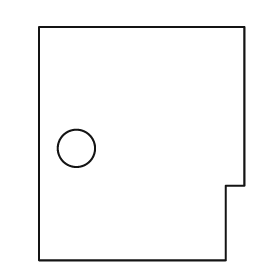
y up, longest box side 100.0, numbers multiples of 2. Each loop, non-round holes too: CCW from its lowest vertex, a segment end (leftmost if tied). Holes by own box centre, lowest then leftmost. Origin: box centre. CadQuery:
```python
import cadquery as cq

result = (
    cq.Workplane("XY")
    .moveTo(-44.0, -50.0)
    .lineTo(36.0, -50.0)
    .lineTo(36.0, -18.0)
    .lineTo(44.0, -18.0)
    .lineTo(44.0, 50.0)
    .lineTo(-44.0, 50.0)
    .close()
    .moveTo(-28.0, -2.0)
    .circle(8.0)
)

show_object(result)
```